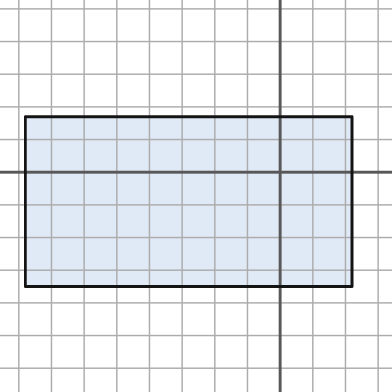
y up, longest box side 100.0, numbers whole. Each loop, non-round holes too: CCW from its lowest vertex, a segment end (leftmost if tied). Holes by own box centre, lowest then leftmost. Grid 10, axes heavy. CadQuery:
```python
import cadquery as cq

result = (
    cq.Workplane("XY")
    .moveTo(-78.0, -35.0)
    .lineTo(22.0, -35.0)
    .lineTo(22.0, 17.0)
    .lineTo(-78.0, 17.0)
    .close()
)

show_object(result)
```